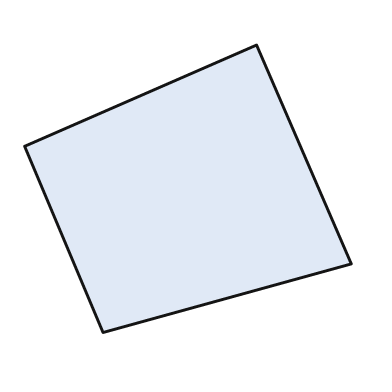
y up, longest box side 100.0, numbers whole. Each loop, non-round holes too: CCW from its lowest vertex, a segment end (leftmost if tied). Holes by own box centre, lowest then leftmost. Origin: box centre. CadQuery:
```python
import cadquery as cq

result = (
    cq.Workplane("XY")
    .moveTo(-26.0, -44.0)
    .lineTo(50.0, -23.0)
    .lineTo(21.0, 44.0)
    .lineTo(-50.0, 13.0)
    .close()
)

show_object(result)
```